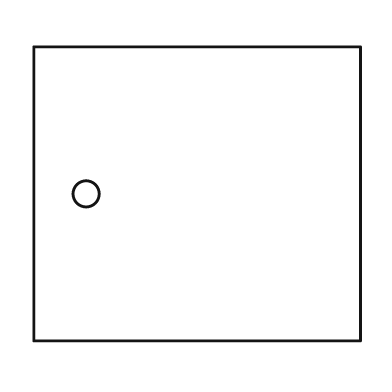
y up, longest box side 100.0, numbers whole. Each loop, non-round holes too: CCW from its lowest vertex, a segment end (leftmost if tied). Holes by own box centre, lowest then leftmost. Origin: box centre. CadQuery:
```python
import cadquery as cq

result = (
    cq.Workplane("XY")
    .moveTo(-50.0, -45.0)
    .lineTo(50.0, -45.0)
    .lineTo(50.0, 45.0)
    .lineTo(-50.0, 45.0)
    .close()
    .moveTo(-34.0, 0.0)
    .circle(4.0)
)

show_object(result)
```